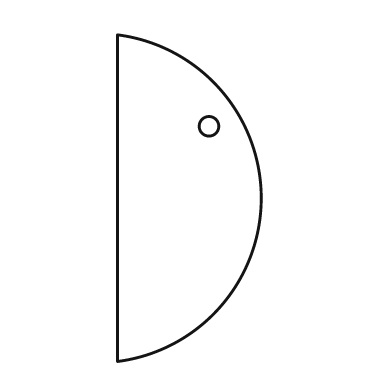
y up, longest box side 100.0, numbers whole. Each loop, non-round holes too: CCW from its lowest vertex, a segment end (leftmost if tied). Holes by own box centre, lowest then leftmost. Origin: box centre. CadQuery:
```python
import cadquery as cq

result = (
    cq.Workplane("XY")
    .moveTo(-22.0, -50.0)
    .threePointArc((22.0, 0.0), (-22.0, 50.0))
    .close()
    .moveTo(6.0, 22.0)
    .circle(3.0)
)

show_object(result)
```